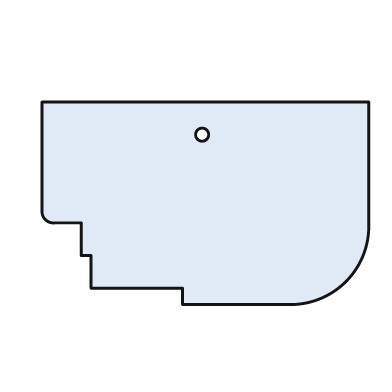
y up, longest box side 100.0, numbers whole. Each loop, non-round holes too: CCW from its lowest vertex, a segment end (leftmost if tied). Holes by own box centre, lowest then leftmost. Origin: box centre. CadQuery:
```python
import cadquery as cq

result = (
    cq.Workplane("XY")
    .moveTo(-7.0, -31.0)
    .lineTo(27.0, -31.0)
    .threePointArc((43.0, -24.0), (50.0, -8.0))
    .lineTo(50.0, 31.0)
    .lineTo(-50.0, 31.0)
    .lineTo(-50.0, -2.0)
    .threePointArc((-49.0, -5.0), (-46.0, -6.0))
    .lineTo(-38.0, -6.0)
    .lineTo(-38.0, -16.0)
    .lineTo(-35.0, -16.0)
    .lineTo(-35.0, -26.0)
    .lineTo(-7.0, -26.0)
    .close()
    .moveTo(-1.0, 21.0)
    .circle(2.0)
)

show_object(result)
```